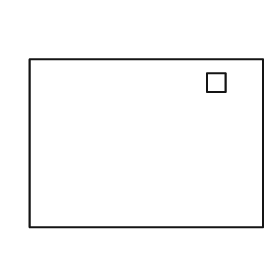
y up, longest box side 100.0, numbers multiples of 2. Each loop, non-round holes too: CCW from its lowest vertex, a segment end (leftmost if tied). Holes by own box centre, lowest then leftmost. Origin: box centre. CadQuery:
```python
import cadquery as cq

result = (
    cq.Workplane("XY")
    .moveTo(-50.0, -36.0)
    .lineTo(50.0, -36.0)
    .lineTo(50.0, 36.0)
    .lineTo(-50.0, 36.0)
    .close()
    .moveTo(26.0, 22.0)
    .lineTo(34.0, 22.0)
    .lineTo(34.0, 30.0)
    .lineTo(26.0, 30.0)
    .close()
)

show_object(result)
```